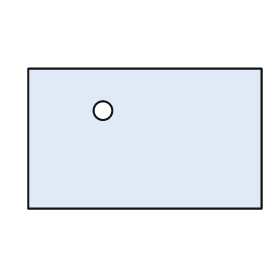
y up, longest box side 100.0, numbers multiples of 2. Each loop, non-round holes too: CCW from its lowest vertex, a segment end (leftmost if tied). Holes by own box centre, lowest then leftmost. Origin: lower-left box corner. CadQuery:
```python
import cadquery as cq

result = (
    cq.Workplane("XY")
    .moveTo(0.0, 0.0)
    .lineTo(100.0, 0.0)
    .lineTo(100.0, 60.0)
    .lineTo(0.0, 60.0)
    .close()
    .moveTo(32.0, 42.0)
    .circle(4.0)
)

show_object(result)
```